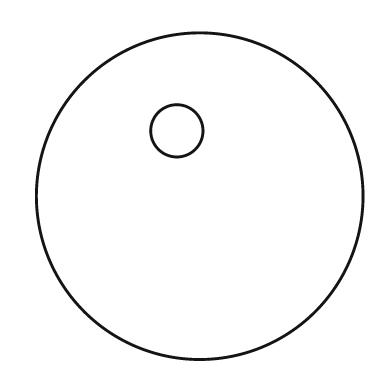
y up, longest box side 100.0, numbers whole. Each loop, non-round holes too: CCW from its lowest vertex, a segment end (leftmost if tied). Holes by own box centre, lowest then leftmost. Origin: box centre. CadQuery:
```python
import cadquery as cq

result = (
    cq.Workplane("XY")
    .moveTo(0.0, 0.0)
    .circle(50.0)
    .moveTo(-7.0, 20.0)
    .circle(8.0)
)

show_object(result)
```